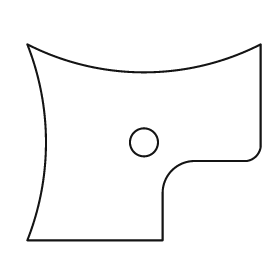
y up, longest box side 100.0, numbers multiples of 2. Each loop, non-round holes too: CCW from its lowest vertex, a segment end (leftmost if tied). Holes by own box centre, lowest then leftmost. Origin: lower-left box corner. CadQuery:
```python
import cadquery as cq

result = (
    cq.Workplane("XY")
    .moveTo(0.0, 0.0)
    .lineTo(58.0, 0.0)
    .lineTo(58.0, 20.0)
    .threePointArc((62.0, 30.0), (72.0, 34.0))
    .lineTo(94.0, 34.0)
    .threePointArc((98.0, 36.0), (100.0, 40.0))
    .lineTo(100.0, 84.0)
    .threePointArc((50.0, 72.0), (0.0, 84.0))
    .threePointArc((8.0, 42.0), (0.0, 0.0))
    .close()
    .moveTo(50.0, 42.0)
    .circle(6.0)
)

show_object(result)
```